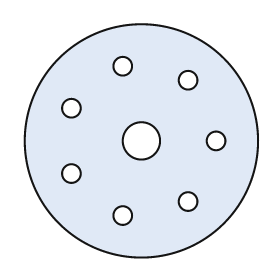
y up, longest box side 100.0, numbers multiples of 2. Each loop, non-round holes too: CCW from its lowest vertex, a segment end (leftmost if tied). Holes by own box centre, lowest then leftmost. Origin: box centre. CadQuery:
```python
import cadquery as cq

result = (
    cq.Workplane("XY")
    .moveTo(0.0, 0.0)
    .circle(50.0)
    .moveTo(-8.0, -32.0)
    .circle(4.0)
    .moveTo(20.0, -26.0)
    .circle(4.0)
    .moveTo(-30.0, -14.0)
    .circle(4.0)
    .moveTo(0.0, 0.0)
    .circle(8.0)
    .moveTo(32.0, 0.0)
    .circle(4.0)
    .moveTo(-30.0, 14.0)
    .circle(4.0)
    .moveTo(20.0, 26.0)
    .circle(4.0)
    .moveTo(-8.0, 32.0)
    .circle(4.0)
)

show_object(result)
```